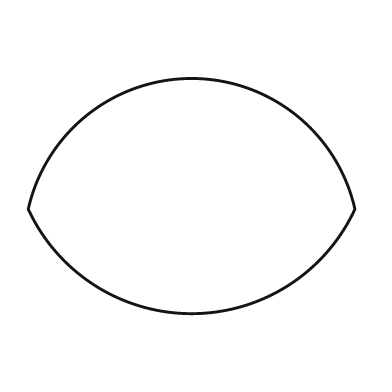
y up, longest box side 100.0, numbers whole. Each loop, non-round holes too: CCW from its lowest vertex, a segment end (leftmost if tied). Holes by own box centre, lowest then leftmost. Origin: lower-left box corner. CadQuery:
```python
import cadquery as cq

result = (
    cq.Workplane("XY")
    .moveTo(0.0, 32.0)
    .threePointArc((50.0, 0.0), (100.0, 32.0))
    .threePointArc((50.0, 72.0), (0.0, 32.0))
    .close()
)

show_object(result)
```